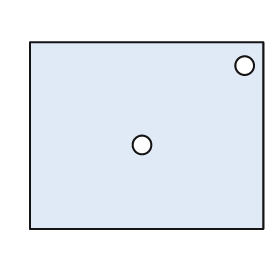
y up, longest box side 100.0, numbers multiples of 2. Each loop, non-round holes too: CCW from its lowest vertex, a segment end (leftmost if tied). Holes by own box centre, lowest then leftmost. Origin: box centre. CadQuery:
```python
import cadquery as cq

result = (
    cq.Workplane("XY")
    .moveTo(-50.0, -40.0)
    .lineTo(50.0, -40.0)
    .lineTo(50.0, 40.0)
    .lineTo(-50.0, 40.0)
    .close()
    .moveTo(-2.0, -4.0)
    .circle(4.0)
    .moveTo(42.0, 30.0)
    .circle(4.0)
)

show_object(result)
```